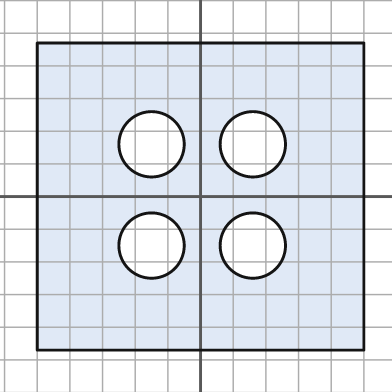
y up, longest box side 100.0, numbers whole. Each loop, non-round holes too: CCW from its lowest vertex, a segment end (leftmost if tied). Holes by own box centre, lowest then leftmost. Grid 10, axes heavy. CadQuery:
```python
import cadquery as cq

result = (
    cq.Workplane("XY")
    .moveTo(-50.0, -47.0)
    .lineTo(50.0, -47.0)
    .lineTo(50.0, 47.0)
    .lineTo(-50.0, 47.0)
    .close()
    .moveTo(-15.0, -15.0)
    .circle(10.0)
    .moveTo(16.0, -15.0)
    .circle(10.0)
    .moveTo(-15.0, 16.0)
    .circle(10.0)
    .moveTo(16.0, 16.0)
    .circle(10.0)
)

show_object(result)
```